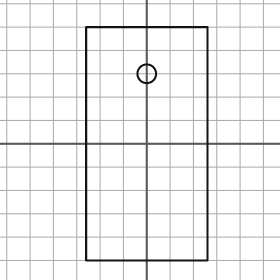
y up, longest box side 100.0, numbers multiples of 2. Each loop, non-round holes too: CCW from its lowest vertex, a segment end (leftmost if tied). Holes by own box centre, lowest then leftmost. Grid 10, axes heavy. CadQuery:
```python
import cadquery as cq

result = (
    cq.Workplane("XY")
    .moveTo(-26.0, -50.0)
    .lineTo(26.0, -50.0)
    .lineTo(26.0, 50.0)
    .lineTo(-26.0, 50.0)
    .close()
    .moveTo(0.0, 30.0)
    .circle(4.0)
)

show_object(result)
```